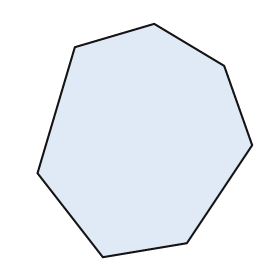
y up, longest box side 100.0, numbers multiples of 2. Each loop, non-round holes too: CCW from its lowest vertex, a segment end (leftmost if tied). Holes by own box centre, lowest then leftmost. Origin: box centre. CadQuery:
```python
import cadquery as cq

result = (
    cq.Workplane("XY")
    .moveTo(-18.0, -50.0)
    .lineTo(18.0, -44.0)
    .lineTo(46.0, -2.0)
    .lineTo(34.0, 32.0)
    .lineTo(4.0, 50.0)
    .lineTo(-30.0, 40.0)
    .lineTo(-46.0, -14.0)
    .close()
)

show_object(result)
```